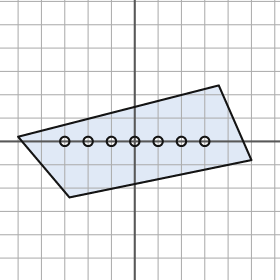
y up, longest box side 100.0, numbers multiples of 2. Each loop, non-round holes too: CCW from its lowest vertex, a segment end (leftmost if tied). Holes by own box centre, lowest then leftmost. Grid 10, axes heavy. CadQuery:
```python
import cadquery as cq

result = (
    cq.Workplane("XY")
    .moveTo(-28.0, -24.0)
    .lineTo(50.0, -8.0)
    .lineTo(36.0, 24.0)
    .lineTo(-50.0, 2.0)
    .close()
    .moveTo(-30.0, 0.0)
    .circle(2.0)
    .moveTo(-20.0, 0.0)
    .circle(2.0)
    .moveTo(-10.0, 0.0)
    .circle(2.0)
    .moveTo(0.0, 0.0)
    .circle(2.0)
    .moveTo(10.0, 0.0)
    .circle(2.0)
    .moveTo(20.0, 0.0)
    .circle(2.0)
    .moveTo(30.0, 0.0)
    .circle(2.0)
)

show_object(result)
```